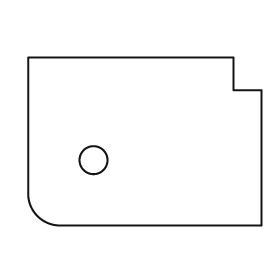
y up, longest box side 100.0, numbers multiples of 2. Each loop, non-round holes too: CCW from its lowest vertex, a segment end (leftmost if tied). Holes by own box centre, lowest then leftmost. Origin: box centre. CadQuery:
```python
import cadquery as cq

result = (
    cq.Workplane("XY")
    .moveTo(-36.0, -36.0)
    .lineTo(50.0, -36.0)
    .lineTo(50.0, 22.0)
    .lineTo(38.0, 22.0)
    .lineTo(38.0, 36.0)
    .lineTo(-50.0, 36.0)
    .lineTo(-50.0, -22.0)
    .threePointArc((-46.0, -32.0), (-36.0, -36.0))
    .close()
    .moveTo(-22.0, -8.0)
    .circle(6.0)
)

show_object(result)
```